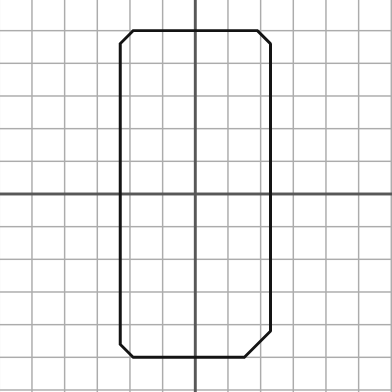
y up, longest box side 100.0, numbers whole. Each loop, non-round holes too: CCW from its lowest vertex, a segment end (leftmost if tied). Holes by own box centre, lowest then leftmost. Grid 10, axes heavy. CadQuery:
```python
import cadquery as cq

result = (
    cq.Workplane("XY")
    .moveTo(-19.0, -50.0)
    .lineTo(15.0, -50.0)
    .lineTo(23.0, -42.0)
    .lineTo(23.0, 46.0)
    .lineTo(19.0, 50.0)
    .lineTo(-19.0, 50.0)
    .lineTo(-23.0, 46.0)
    .lineTo(-23.0, -46.0)
    .close()
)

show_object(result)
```